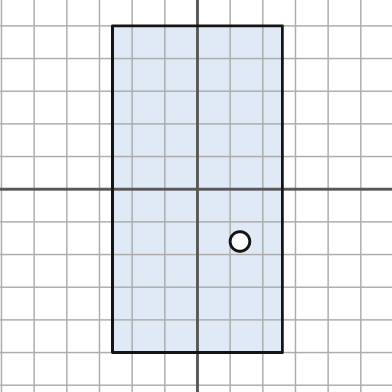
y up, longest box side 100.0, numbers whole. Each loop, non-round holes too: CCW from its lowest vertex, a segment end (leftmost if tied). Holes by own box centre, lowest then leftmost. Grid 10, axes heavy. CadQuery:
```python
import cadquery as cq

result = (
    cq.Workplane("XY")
    .moveTo(-26.0, -50.0)
    .lineTo(26.0, -50.0)
    .lineTo(26.0, 50.0)
    .lineTo(-26.0, 50.0)
    .close()
    .moveTo(13.0, -16.0)
    .circle(3.0)
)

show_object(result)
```